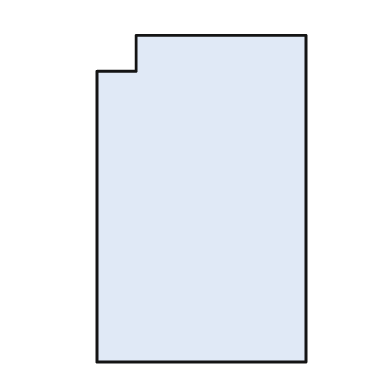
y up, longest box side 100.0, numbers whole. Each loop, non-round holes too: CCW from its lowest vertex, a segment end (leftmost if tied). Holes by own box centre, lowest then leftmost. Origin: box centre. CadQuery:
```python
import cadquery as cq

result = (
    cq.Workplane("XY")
    .moveTo(-32.0, -50.0)
    .lineTo(32.0, -50.0)
    .lineTo(32.0, 50.0)
    .lineTo(-20.0, 50.0)
    .lineTo(-20.0, 39.0)
    .lineTo(-32.0, 39.0)
    .close()
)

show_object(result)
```